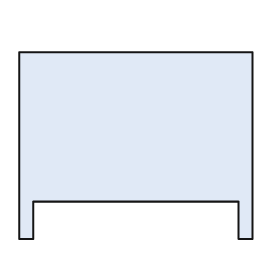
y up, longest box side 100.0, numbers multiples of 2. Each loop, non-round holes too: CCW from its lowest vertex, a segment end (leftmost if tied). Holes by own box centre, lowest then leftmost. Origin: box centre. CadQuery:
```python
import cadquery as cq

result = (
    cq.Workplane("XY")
    .moveTo(-50.0, -40.0)
    .lineTo(-44.0, -40.0)
    .lineTo(-44.0, -24.0)
    .lineTo(44.0, -24.0)
    .lineTo(44.0, -40.0)
    .lineTo(50.0, -40.0)
    .lineTo(50.0, 40.0)
    .lineTo(-50.0, 40.0)
    .close()
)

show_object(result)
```